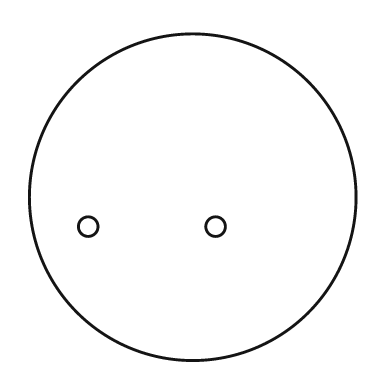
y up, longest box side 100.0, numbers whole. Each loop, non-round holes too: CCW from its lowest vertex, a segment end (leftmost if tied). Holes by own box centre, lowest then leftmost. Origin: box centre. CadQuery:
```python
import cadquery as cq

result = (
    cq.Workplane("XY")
    .moveTo(0.0, 0.0)
    .circle(50.0)
    .moveTo(-32.0, -9.0)
    .circle(3.0)
    .moveTo(7.0, -9.0)
    .circle(3.0)
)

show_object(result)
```